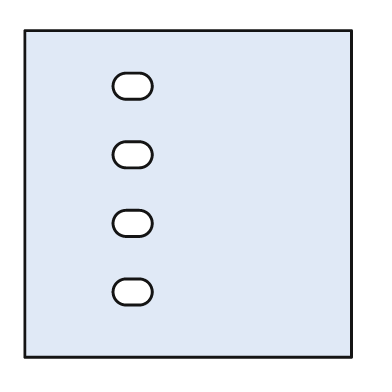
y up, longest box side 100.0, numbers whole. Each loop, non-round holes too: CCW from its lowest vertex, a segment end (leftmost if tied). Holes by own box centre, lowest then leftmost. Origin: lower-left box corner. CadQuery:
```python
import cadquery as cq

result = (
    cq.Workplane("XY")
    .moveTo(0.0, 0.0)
    .lineTo(100.0, 0.0)
    .lineTo(100.0, 100.0)
    .lineTo(0.0, 100.0)
    .close()
    .moveTo(31.0, 16.0)
    .lineTo(35.0, 16.0)
    .threePointArc((39.0, 20.0), (35.0, 24.0))
    .lineTo(31.0, 24.0)
    .threePointArc((27.0, 20.0), (31.0, 16.0))
    .close()
    .moveTo(31.0, 37.0)
    .lineTo(35.0, 37.0)
    .threePointArc((39.0, 41.0), (35.0, 45.0))
    .lineTo(31.0, 45.0)
    .threePointArc((27.0, 41.0), (31.0, 37.0))
    .close()
    .moveTo(31.0, 58.0)
    .lineTo(35.0, 58.0)
    .threePointArc((39.0, 62.0), (35.0, 66.0))
    .lineTo(31.0, 66.0)
    .threePointArc((27.0, 62.0), (31.0, 58.0))
    .close()
    .moveTo(31.0, 79.0)
    .lineTo(35.0, 79.0)
    .threePointArc((39.0, 83.0), (35.0, 87.0))
    .lineTo(31.0, 87.0)
    .threePointArc((27.0, 83.0), (31.0, 79.0))
    .close()
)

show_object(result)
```